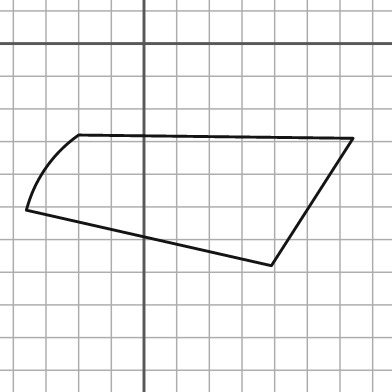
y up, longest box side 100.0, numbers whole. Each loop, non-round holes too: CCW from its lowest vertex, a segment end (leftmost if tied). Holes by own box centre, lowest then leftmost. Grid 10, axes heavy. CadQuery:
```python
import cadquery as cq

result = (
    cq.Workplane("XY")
    .moveTo(39.0, -68.0)
    .lineTo(64.0, -29.0)
    .lineTo(-20.0, -28.0)
    .threePointArc((-30.0, -38.0), (-36.0, -51.0))
    .close()
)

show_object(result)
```